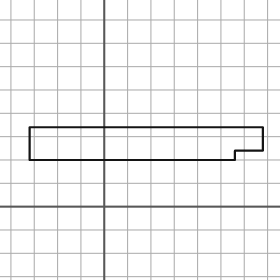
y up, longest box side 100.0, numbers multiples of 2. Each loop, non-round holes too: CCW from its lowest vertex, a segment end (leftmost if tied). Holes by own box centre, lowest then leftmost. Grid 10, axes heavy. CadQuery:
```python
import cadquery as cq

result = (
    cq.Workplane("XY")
    .moveTo(-32.0, 20.0)
    .lineTo(56.0, 20.0)
    .lineTo(56.0, 24.0)
    .lineTo(68.0, 24.0)
    .lineTo(68.0, 34.0)
    .lineTo(-32.0, 34.0)
    .close()
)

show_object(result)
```